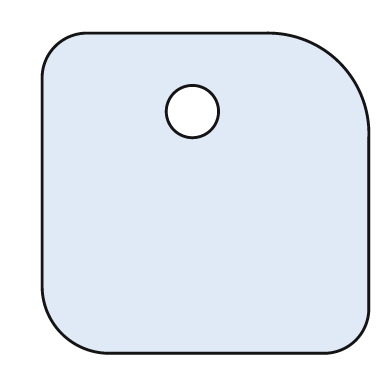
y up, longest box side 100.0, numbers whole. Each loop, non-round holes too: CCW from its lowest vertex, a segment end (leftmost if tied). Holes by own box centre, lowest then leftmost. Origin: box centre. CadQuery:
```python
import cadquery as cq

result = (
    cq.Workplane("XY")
    .moveTo(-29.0, -49.0)
    .lineTo(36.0, -49.0)
    .threePointArc((46.0, -45.0), (50.0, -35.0))
    .lineTo(50.0, 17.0)
    .threePointArc((41.0, 40.0), (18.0, 49.0))
    .lineTo(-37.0, 49.0)
    .threePointArc((-46.0, 45.0), (-50.0, 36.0))
    .lineTo(-50.0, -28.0)
    .threePointArc((-44.0, -43.0), (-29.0, -49.0))
    .close()
    .moveTo(-4.0, 25.0)
    .circle(8.0)
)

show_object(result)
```